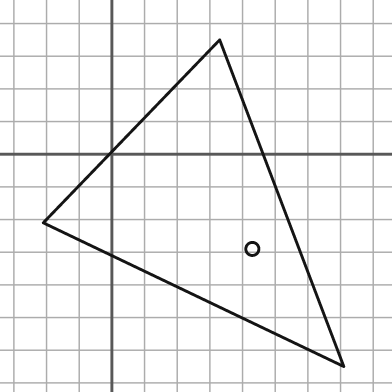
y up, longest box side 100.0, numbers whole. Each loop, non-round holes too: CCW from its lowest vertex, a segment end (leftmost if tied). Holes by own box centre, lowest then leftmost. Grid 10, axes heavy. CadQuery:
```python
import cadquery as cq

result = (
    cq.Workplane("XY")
    .moveTo(71.0, -65.0)
    .lineTo(33.0, 35.0)
    .lineTo(-21.0, -21.0)
    .close()
    .moveTo(43.0, -29.0)
    .circle(2.0)
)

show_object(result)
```